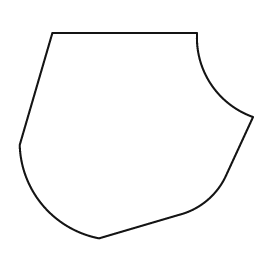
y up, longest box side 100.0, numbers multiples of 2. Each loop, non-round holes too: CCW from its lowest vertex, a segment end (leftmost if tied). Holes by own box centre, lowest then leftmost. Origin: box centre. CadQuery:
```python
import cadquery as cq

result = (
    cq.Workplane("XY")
    .moveTo(-16.0, -44.0)
    .lineTo(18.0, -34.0)
    .threePointArc((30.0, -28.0), (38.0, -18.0))
    .lineTo(50.0, 8.0)
    .threePointArc((32.0, 22.0), (26.0, 44.0))
    .lineTo(-36.0, 44.0)
    .lineTo(-50.0, -4.0)
    .threePointArc((-40.0, -30.0), (-16.0, -44.0))
    .close()
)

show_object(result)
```